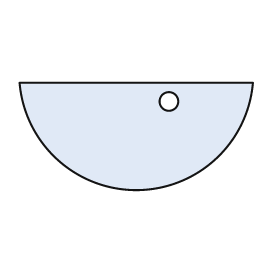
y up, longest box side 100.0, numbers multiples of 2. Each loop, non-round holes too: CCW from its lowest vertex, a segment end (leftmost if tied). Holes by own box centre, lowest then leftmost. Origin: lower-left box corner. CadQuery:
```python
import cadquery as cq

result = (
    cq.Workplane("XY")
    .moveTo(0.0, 46.0)
    .threePointArc((50.0, 0.0), (100.0, 46.0))
    .close()
    .moveTo(64.0, 38.0)
    .circle(4.0)
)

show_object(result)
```